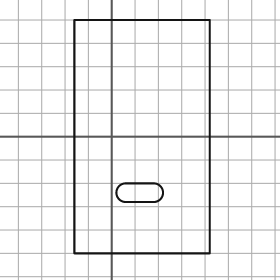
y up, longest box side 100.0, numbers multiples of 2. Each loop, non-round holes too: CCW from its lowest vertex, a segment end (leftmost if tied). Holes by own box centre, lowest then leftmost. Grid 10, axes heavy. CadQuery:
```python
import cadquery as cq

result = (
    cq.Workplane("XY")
    .moveTo(-16.0, -50.0)
    .lineTo(42.0, -50.0)
    .lineTo(42.0, 50.0)
    .lineTo(-16.0, 50.0)
    .close()
    .moveTo(6.0, -28.0)
    .lineTo(18.0, -28.0)
    .threePointArc((22.0, -24.0), (18.0, -20.0))
    .lineTo(6.0, -20.0)
    .threePointArc((2.0, -24.0), (6.0, -28.0))
    .close()
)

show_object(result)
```